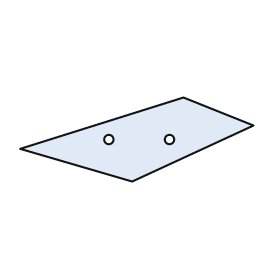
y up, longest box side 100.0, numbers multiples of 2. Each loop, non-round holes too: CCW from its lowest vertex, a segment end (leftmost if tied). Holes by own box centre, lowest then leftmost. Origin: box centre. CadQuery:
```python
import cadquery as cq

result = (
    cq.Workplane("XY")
    .moveTo(-2.0, -18.0)
    .lineTo(50.0, 6.0)
    .lineTo(20.0, 18.0)
    .lineTo(-50.0, -4.0)
    .close()
    .moveTo(-12.0, 0.0)
    .circle(2.0)
    .moveTo(14.0, 0.0)
    .circle(2.0)
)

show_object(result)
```